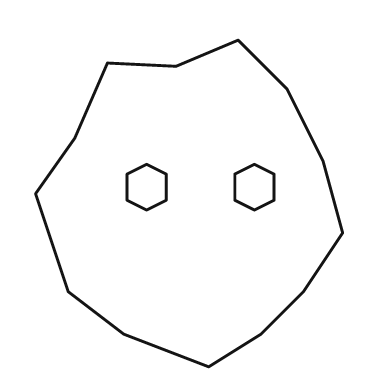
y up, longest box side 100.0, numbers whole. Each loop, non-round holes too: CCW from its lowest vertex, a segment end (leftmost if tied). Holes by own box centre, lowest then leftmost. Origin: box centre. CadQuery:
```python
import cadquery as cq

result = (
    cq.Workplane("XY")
    .moveTo(6.0, -50.0)
    .lineTo(22.0, -40.0)
    .lineTo(35.0, -27.0)
    .lineTo(47.0, -9.0)
    .lineTo(41.0, 13.0)
    .lineTo(30.0, 35.0)
    .lineTo(15.0, 50.0)
    .lineTo(-4.0, 42.0)
    .lineTo(-25.0, 43.0)
    .lineTo(-35.0, 20.0)
    .lineTo(-47.0, 3.0)
    .lineTo(-37.0, -27.0)
    .lineTo(-20.0, -40.0)
    .close()
    .moveTo(-13.0, -2.0)
    .lineTo(-7.0, 1.0)
    .lineTo(-7.0, 9.0)
    .lineTo(-13.0, 12.0)
    .lineTo(-19.0, 9.0)
    .lineTo(-19.0, 1.0)
    .close()
    .moveTo(20.0, -2.0)
    .lineTo(26.0, 1.0)
    .lineTo(26.0, 9.0)
    .lineTo(20.0, 12.0)
    .lineTo(14.0, 9.0)
    .lineTo(14.0, 1.0)
    .close()
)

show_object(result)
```